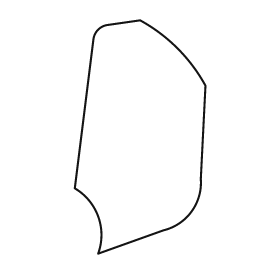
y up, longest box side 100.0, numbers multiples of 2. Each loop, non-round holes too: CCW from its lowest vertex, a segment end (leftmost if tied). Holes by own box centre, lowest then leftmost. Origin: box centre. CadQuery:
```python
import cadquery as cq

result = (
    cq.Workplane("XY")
    .moveTo(-18.0, -50.0)
    .lineTo(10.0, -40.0)
    .threePointArc((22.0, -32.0), (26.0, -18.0))
    .lineTo(28.0, 22.0)
    .threePointArc((16.0, 38.0), (0.0, 50.0))
    .lineTo(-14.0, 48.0)
    .threePointArc((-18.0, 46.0), (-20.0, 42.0))
    .lineTo(-28.0, -22.0)
    .threePointArc((-18.0, -34.0), (-18.0, -50.0))
    .close()
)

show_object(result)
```